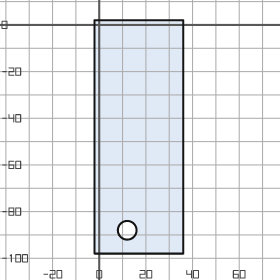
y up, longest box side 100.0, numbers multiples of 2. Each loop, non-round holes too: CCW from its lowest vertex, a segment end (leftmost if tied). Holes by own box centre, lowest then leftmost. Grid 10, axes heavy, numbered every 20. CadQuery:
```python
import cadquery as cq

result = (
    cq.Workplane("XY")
    .moveTo(-2.0, -98.0)
    .lineTo(36.0, -98.0)
    .lineTo(36.0, 2.0)
    .lineTo(-2.0, 2.0)
    .close()
    .moveTo(12.0, -88.0)
    .circle(4.0)
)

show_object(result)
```